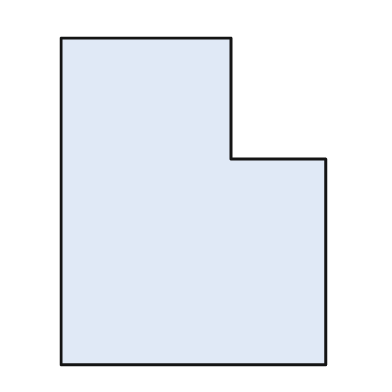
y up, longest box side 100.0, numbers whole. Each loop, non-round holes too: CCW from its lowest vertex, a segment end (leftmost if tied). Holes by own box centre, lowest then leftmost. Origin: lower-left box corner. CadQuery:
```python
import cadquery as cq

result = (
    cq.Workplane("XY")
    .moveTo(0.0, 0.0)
    .lineTo(81.0, 0.0)
    .lineTo(81.0, 63.0)
    .lineTo(52.0, 63.0)
    .lineTo(52.0, 100.0)
    .lineTo(0.0, 100.0)
    .close()
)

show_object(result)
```